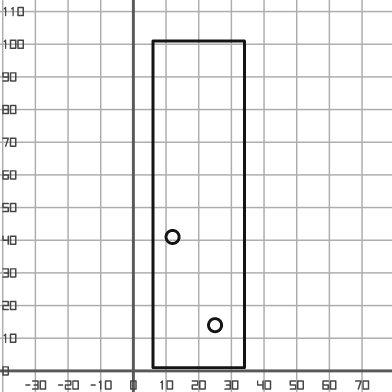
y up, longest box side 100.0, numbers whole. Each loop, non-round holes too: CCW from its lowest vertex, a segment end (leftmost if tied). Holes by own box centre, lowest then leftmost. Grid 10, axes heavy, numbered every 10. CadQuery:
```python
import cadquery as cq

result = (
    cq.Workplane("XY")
    .moveTo(6.0, 1.0)
    .lineTo(34.0, 1.0)
    .lineTo(34.0, 101.0)
    .lineTo(6.0, 101.0)
    .close()
    .moveTo(25.0, 14.0)
    .circle(2.0)
    .moveTo(12.0, 41.0)
    .circle(2.0)
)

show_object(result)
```